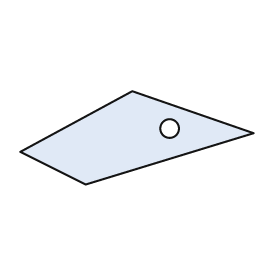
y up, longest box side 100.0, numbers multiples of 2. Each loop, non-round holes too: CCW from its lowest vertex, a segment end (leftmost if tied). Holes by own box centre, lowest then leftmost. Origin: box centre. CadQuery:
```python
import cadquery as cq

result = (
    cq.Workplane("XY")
    .moveTo(-22.0, -20.0)
    .lineTo(50.0, 2.0)
    .lineTo(-2.0, 20.0)
    .lineTo(-50.0, -6.0)
    .close()
    .moveTo(14.0, 4.0)
    .circle(4.0)
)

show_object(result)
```